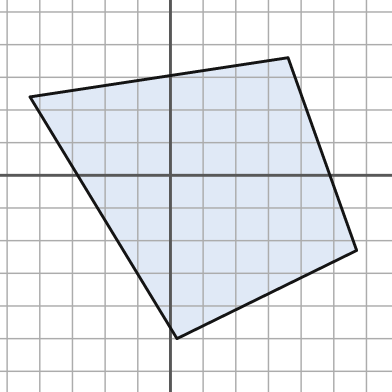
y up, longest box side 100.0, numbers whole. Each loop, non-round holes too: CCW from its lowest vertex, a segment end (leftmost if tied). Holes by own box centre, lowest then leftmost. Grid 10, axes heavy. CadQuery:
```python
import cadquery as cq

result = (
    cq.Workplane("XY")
    .moveTo(2.0, -50.0)
    .lineTo(57.0, -23.0)
    .lineTo(36.0, 36.0)
    .lineTo(-43.0, 24.0)
    .close()
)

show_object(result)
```